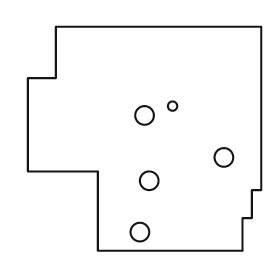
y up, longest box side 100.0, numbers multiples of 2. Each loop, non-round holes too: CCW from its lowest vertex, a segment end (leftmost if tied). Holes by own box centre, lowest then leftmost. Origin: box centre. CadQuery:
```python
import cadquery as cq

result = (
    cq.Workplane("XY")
    .moveTo(-20.0, -48.0)
    .lineTo(42.0, -48.0)
    .lineTo(42.0, -34.0)
    .lineTo(46.0, -34.0)
    .lineTo(46.0, -22.0)
    .lineTo(50.0, -22.0)
    .lineTo(50.0, 48.0)
    .lineTo(-38.0, 48.0)
    .lineTo(-38.0, 26.0)
    .lineTo(-50.0, 26.0)
    .lineTo(-50.0, -14.0)
    .lineTo(-20.0, -14.0)
    .close()
    .moveTo(-2.0, -40.0)
    .circle(4.0)
    .moveTo(2.0, -18.0)
    .circle(4.0)
    .moveTo(34.0, -8.0)
    .circle(4.0)
    .moveTo(0.0, 10.0)
    .circle(4.0)
    .moveTo(12.0, 14.0)
    .circle(2.0)
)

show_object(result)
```